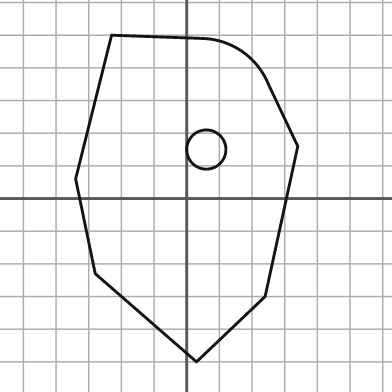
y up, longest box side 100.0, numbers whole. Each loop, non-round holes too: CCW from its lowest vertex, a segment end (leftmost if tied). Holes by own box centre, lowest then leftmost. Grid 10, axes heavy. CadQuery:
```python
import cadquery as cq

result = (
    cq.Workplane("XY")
    .moveTo(3.0, -50.0)
    .lineTo(24.0, -30.0)
    .lineTo(34.0, 16.0)
    .lineTo(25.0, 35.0)
    .threePointArc((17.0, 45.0), (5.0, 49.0))
    .lineTo(-23.0, 50.0)
    .lineTo(-34.0, 6.0)
    .lineTo(-28.0, -23.0)
    .close()
    .moveTo(6.0, 15.0)
    .circle(6.0)
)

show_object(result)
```